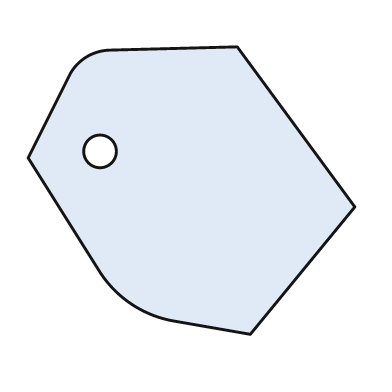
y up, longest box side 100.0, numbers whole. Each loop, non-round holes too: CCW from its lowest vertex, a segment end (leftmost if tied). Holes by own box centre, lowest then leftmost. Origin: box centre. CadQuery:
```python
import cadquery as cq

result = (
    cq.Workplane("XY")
    .moveTo(18.0, -44.0)
    .lineTo(50.0, -5.0)
    .lineTo(14.0, 44.0)
    .lineTo(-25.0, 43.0)
    .threePointArc((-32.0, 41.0), (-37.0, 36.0))
    .lineTo(-50.0, 10.0)
    .lineTo(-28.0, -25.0)
    .threePointArc((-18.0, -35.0), (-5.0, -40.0))
    .close()
    .moveTo(-28.0, 12.0)
    .circle(5.0)
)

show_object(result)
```